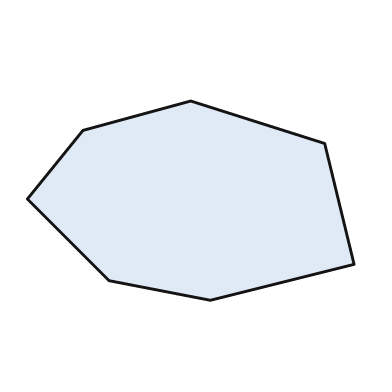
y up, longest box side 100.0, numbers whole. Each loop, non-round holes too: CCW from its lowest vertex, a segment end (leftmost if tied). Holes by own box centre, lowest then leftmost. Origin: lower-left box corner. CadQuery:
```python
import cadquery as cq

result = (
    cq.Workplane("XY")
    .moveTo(56.0, 0.0)
    .lineTo(100.0, 11.0)
    .lineTo(91.0, 48.0)
    .lineTo(50.0, 61.0)
    .lineTo(17.0, 52.0)
    .lineTo(0.0, 31.0)
    .lineTo(25.0, 6.0)
    .close()
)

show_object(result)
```